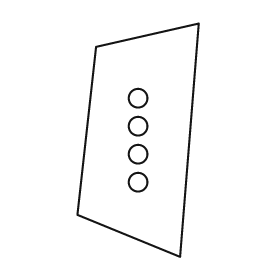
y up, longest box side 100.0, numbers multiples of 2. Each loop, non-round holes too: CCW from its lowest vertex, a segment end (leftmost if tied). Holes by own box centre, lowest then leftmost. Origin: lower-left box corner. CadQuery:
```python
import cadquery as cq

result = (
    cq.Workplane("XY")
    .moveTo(44.0, 0.0)
    .lineTo(52.0, 100.0)
    .lineTo(8.0, 90.0)
    .lineTo(0.0, 18.0)
    .close()
    .moveTo(26.0, 32.0)
    .circle(4.0)
    .moveTo(26.0, 44.0)
    .circle(4.0)
    .moveTo(26.0, 56.0)
    .circle(4.0)
    .moveTo(26.0, 68.0)
    .circle(4.0)
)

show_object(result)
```